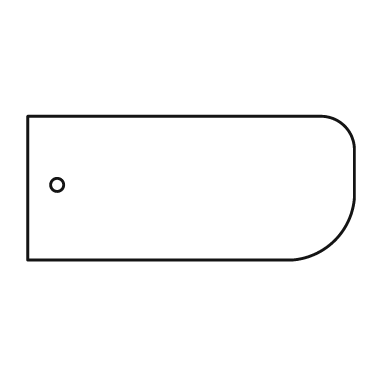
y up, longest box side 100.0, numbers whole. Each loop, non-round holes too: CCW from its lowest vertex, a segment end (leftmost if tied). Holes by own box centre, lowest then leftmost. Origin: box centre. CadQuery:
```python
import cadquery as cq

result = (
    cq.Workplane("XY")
    .moveTo(-50.0, -22.0)
    .lineTo(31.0, -22.0)
    .threePointArc((44.0, -16.0), (50.0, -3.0))
    .lineTo(50.0, 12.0)
    .threePointArc((47.0, 19.0), (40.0, 22.0))
    .lineTo(-50.0, 22.0)
    .close()
    .moveTo(-41.0, 1.0)
    .circle(2.0)
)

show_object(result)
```